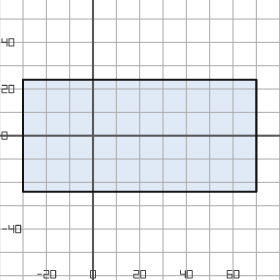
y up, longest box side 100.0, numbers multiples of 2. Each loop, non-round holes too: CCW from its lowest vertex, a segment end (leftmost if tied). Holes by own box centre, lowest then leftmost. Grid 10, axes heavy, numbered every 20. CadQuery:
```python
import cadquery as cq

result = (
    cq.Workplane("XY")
    .moveTo(-30.0, -24.0)
    .lineTo(70.0, -24.0)
    .lineTo(70.0, 24.0)
    .lineTo(-30.0, 24.0)
    .close()
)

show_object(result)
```